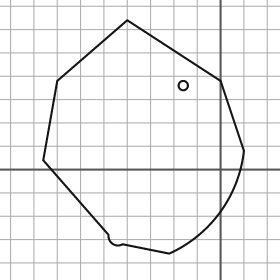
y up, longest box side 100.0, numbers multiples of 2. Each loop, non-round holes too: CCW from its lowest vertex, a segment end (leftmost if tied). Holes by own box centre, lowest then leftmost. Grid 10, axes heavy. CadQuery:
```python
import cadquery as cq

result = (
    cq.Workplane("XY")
    .moveTo(-22.0, -36.0)
    .threePointArc((0.0, -18.0), (10.0, 8.0))
    .lineTo(0.0, 38.0)
    .lineTo(-40.0, 64.0)
    .lineTo(-70.0, 38.0)
    .lineTo(-76.0, 4.0)
    .lineTo(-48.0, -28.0)
    .threePointArc((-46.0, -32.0), (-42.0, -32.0))
    .close()
    .moveTo(-16.0, 36.0)
    .circle(2.0)
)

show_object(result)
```